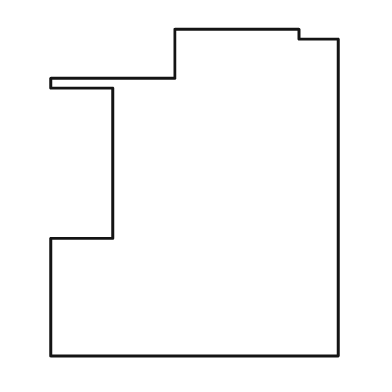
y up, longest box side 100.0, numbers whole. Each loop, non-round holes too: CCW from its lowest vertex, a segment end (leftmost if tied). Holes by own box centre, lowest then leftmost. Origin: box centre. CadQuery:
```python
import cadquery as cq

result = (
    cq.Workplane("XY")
    .moveTo(-44.0, -50.0)
    .lineTo(44.0, -50.0)
    .lineTo(44.0, 47.0)
    .lineTo(32.0, 47.0)
    .lineTo(32.0, 50.0)
    .lineTo(-6.0, 50.0)
    .lineTo(-6.0, 35.0)
    .lineTo(-44.0, 35.0)
    .lineTo(-44.0, 32.0)
    .lineTo(-25.0, 32.0)
    .lineTo(-25.0, -14.0)
    .lineTo(-44.0, -14.0)
    .close()
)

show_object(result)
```